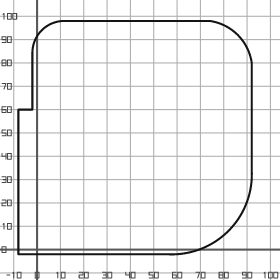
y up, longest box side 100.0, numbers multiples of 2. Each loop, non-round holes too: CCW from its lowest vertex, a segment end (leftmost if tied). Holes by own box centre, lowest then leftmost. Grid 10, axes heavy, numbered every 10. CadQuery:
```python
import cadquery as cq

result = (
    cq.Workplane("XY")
    .moveTo(-8.0, -2.0)
    .lineTo(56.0, -2.0)
    .threePointArc((82.0, 8.0), (92.0, 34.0))
    .lineTo(92.0, 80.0)
    .threePointArc((86.0, 92.0), (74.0, 98.0))
    .lineTo(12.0, 98.0)
    .threePointArc((2.0, 94.0), (-2.0, 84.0))
    .lineTo(-2.0, 60.0)
    .lineTo(-8.0, 60.0)
    .close()
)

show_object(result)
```